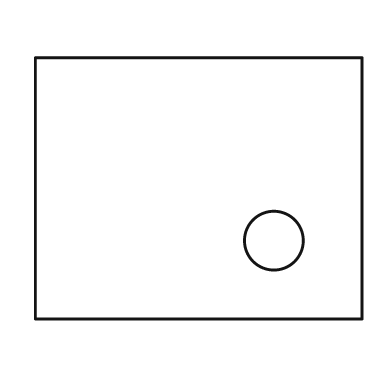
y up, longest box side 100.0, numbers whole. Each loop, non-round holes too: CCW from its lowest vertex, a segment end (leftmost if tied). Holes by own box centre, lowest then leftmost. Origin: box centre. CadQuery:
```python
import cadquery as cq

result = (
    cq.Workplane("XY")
    .moveTo(-50.0, -40.0)
    .lineTo(50.0, -40.0)
    .lineTo(50.0, 40.0)
    .lineTo(-50.0, 40.0)
    .close()
    .moveTo(23.0, -16.0)
    .circle(9.0)
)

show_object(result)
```